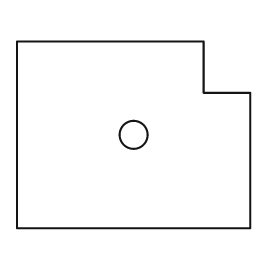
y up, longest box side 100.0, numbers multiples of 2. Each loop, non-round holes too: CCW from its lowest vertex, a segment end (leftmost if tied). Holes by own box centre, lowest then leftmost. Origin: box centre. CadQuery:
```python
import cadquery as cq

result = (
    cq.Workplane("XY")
    .moveTo(-50.0, -40.0)
    .lineTo(50.0, -40.0)
    .lineTo(50.0, 18.0)
    .lineTo(30.0, 18.0)
    .lineTo(30.0, 40.0)
    .lineTo(-50.0, 40.0)
    .close()
    .moveTo(0.0, 0.0)
    .circle(6.0)
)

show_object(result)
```